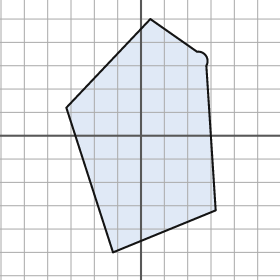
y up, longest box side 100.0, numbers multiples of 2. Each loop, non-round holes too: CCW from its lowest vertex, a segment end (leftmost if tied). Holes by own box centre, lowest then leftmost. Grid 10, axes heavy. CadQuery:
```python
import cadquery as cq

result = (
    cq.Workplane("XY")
    .moveTo(-12.0, -50.0)
    .lineTo(32.0, -32.0)
    .lineTo(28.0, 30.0)
    .threePointArc((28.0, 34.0), (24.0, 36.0))
    .lineTo(4.0, 50.0)
    .lineTo(-32.0, 12.0)
    .close()
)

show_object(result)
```